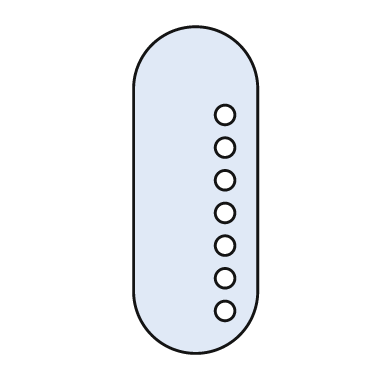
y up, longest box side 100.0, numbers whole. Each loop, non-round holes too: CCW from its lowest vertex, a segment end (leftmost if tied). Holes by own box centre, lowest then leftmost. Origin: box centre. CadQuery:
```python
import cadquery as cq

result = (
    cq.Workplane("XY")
    .moveTo(-19.0, -31.0)
    .threePointArc((0.0, -50.0), (19.0, -31.0))
    .lineTo(19.0, 31.0)
    .threePointArc((0.0, 50.0), (-19.0, 31.0))
    .close()
    .moveTo(9.0, -37.0)
    .circle(3.0)
    .moveTo(9.0, -27.0)
    .circle(3.0)
    .moveTo(9.0, -17.0)
    .circle(3.0)
    .moveTo(9.0, -7.0)
    .circle(3.0)
    .moveTo(9.0, 3.0)
    .circle(3.0)
    .moveTo(9.0, 13.0)
    .circle(3.0)
    .moveTo(9.0, 23.0)
    .circle(3.0)
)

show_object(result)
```